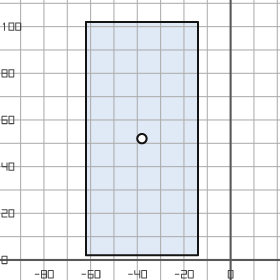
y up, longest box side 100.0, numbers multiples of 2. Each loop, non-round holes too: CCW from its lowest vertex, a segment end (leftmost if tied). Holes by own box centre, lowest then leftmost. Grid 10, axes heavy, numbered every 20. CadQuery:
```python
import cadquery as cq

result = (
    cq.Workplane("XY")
    .moveTo(-62.0, 2.0)
    .lineTo(-14.0, 2.0)
    .lineTo(-14.0, 102.0)
    .lineTo(-62.0, 102.0)
    .close()
    .moveTo(-38.0, 52.0)
    .circle(2.0)
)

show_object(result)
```